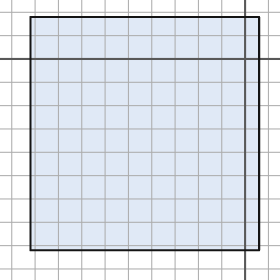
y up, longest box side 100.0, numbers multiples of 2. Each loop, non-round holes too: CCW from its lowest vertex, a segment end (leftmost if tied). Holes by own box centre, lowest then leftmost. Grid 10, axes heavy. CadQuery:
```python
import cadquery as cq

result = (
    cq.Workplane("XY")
    .moveTo(-92.0, -82.0)
    .lineTo(6.0, -82.0)
    .lineTo(6.0, 18.0)
    .lineTo(-92.0, 18.0)
    .close()
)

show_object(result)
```